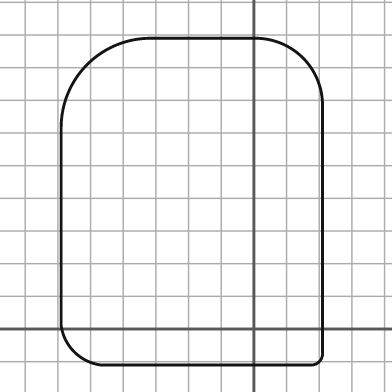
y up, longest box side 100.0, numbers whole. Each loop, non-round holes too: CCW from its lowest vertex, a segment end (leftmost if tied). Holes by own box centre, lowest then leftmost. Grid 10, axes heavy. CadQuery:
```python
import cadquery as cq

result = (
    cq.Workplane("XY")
    .moveTo(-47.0, -11.0)
    .lineTo(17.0, -11.0)
    .threePointArc((20.0, -10.0), (21.0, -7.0))
    .lineTo(21.0, 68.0)
    .threePointArc((15.0, 83.0), (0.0, 89.0))
    .lineTo(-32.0, 89.0)
    .threePointArc((-51.0, 81.0), (-59.0, 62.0))
    .lineTo(-59.0, 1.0)
    .threePointArc((-55.0, -7.0), (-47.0, -11.0))
    .close()
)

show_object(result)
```